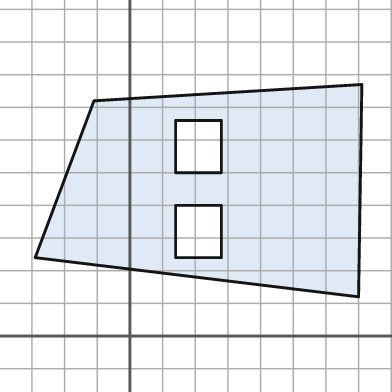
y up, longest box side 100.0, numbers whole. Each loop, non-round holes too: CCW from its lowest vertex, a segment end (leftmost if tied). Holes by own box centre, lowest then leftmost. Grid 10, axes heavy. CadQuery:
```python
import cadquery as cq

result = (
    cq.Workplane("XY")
    .moveTo(70.0, 12.0)
    .lineTo(71.0, 77.0)
    .lineTo(-11.0, 72.0)
    .lineTo(-29.0, 24.0)
    .close()
    .moveTo(14.0, 24.0)
    .lineTo(28.0, 24.0)
    .lineTo(28.0, 40.0)
    .lineTo(14.0, 40.0)
    .close()
    .moveTo(14.0, 50.0)
    .lineTo(28.0, 50.0)
    .lineTo(28.0, 66.0)
    .lineTo(14.0, 66.0)
    .close()
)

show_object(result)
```